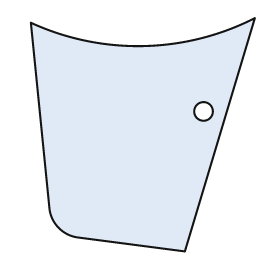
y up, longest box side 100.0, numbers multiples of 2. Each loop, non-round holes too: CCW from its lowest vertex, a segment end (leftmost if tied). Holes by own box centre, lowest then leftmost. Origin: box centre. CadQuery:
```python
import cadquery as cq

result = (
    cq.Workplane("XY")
    .moveTo(18.0, -50.0)
    .lineTo(48.0, 50.0)
    .threePointArc((0.0, 38.0), (-48.0, 48.0))
    .lineTo(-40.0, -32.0)
    .threePointArc((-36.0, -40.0), (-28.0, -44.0))
    .close()
    .moveTo(26.0, 10.0)
    .circle(4.0)
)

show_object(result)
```